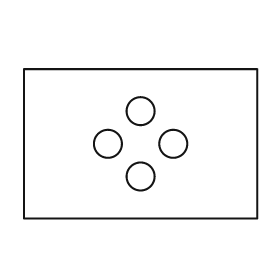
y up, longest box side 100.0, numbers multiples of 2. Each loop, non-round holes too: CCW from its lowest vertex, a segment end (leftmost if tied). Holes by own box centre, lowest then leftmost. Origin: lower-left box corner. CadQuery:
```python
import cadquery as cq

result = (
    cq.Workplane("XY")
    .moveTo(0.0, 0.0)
    .lineTo(100.0, 0.0)
    .lineTo(100.0, 64.0)
    .lineTo(0.0, 64.0)
    .close()
    .moveTo(50.0, 18.0)
    .circle(6.0)
    .moveTo(36.0, 32.0)
    .circle(6.0)
    .moveTo(64.0, 32.0)
    .circle(6.0)
    .moveTo(50.0, 46.0)
    .circle(6.0)
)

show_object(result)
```